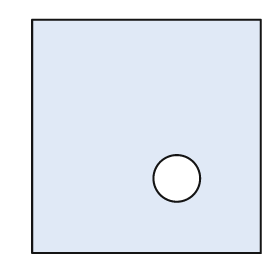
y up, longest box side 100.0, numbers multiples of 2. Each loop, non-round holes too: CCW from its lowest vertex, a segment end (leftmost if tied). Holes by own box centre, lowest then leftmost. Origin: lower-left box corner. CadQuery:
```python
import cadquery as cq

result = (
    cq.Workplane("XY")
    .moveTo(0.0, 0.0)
    .lineTo(98.0, 0.0)
    .lineTo(98.0, 100.0)
    .lineTo(0.0, 100.0)
    .close()
    .moveTo(62.0, 32.0)
    .circle(10.0)
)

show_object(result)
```